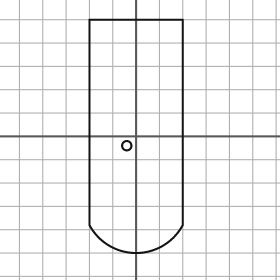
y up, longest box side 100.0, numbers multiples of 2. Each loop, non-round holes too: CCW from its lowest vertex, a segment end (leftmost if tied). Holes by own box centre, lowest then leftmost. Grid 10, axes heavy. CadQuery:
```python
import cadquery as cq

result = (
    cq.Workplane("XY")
    .moveTo(-20.0, -38.0)
    .threePointArc((0.0, -50.0), (20.0, -38.0))
    .lineTo(20.0, 50.0)
    .lineTo(-20.0, 50.0)
    .close()
    .moveTo(-4.0, -4.0)
    .circle(2.0)
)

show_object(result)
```